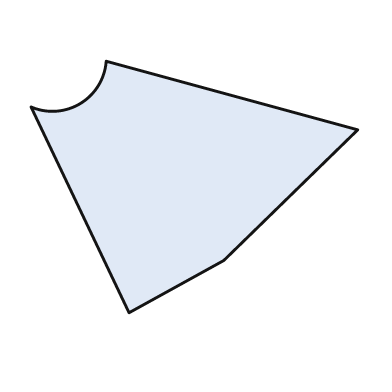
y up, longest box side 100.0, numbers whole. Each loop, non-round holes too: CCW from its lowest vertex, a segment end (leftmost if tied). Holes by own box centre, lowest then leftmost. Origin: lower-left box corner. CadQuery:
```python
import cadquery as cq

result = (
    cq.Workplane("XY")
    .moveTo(30.0, 0.0)
    .lineTo(59.0, 16.0)
    .lineTo(100.0, 56.0)
    .lineTo(23.0, 77.0)
    .threePointArc((15.0, 64.0), (0.0, 63.0))
    .close()
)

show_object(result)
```